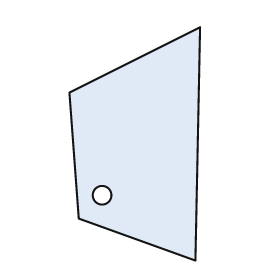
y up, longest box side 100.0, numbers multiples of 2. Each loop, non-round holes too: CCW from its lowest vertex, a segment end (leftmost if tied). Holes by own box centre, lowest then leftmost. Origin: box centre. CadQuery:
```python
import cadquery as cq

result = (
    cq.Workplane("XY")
    .moveTo(26.0, -50.0)
    .lineTo(28.0, 50.0)
    .lineTo(-28.0, 22.0)
    .lineTo(-24.0, -32.0)
    .close()
    .moveTo(-14.0, -22.0)
    .circle(4.0)
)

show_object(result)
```